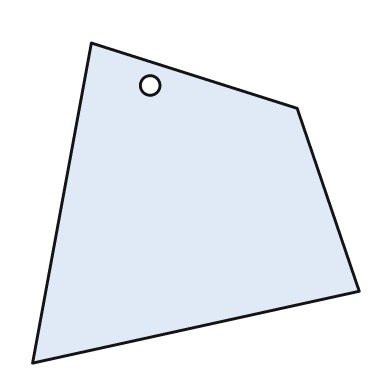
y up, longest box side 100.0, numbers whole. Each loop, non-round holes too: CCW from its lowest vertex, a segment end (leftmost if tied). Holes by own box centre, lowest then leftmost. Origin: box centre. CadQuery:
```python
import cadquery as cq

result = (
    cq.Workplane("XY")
    .moveTo(-50.0, -49.0)
    .lineTo(50.0, -27.0)
    .lineTo(31.0, 29.0)
    .lineTo(-32.0, 49.0)
    .close()
    .moveTo(-14.0, 36.0)
    .circle(3.0)
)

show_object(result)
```